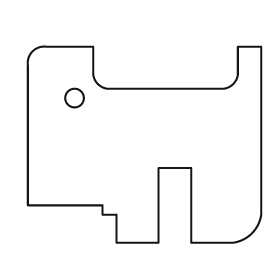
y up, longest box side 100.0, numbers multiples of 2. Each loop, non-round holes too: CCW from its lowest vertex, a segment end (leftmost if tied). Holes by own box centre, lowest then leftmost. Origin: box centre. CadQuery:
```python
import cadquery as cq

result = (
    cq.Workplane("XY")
    .moveTo(-12.0, -42.0)
    .lineTo(6.0, -42.0)
    .lineTo(6.0, -10.0)
    .lineTo(20.0, -10.0)
    .lineTo(20.0, -42.0)
    .lineTo(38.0, -42.0)
    .threePointArc((46.0, -38.0), (50.0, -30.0))
    .lineTo(50.0, 42.0)
    .lineTo(40.0, 42.0)
    .lineTo(40.0, 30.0)
    .threePointArc((38.0, 26.0), (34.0, 24.0))
    .lineTo(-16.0, 24.0)
    .threePointArc((-20.0, 26.0), (-22.0, 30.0))
    .lineTo(-22.0, 42.0)
    .lineTo(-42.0, 42.0)
    .threePointArc((-48.0, 40.0), (-50.0, 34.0))
    .lineTo(-50.0, -26.0)
    .lineTo(-18.0, -26.0)
    .lineTo(-18.0, -30.0)
    .lineTo(-12.0, -30.0)
    .close()
    .moveTo(-30.0, 20.0)
    .circle(4.0)
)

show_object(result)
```